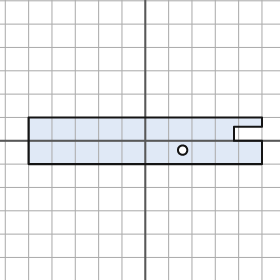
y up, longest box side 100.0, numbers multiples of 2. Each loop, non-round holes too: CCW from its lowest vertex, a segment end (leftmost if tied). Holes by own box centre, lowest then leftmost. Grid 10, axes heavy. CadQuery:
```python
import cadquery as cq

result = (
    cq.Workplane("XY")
    .moveTo(-50.0, -10.0)
    .lineTo(50.0, -10.0)
    .lineTo(50.0, 0.0)
    .lineTo(38.0, 0.0)
    .lineTo(38.0, 6.0)
    .lineTo(50.0, 6.0)
    .lineTo(50.0, 10.0)
    .lineTo(-50.0, 10.0)
    .close()
    .moveTo(16.0, -4.0)
    .circle(2.0)
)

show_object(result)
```